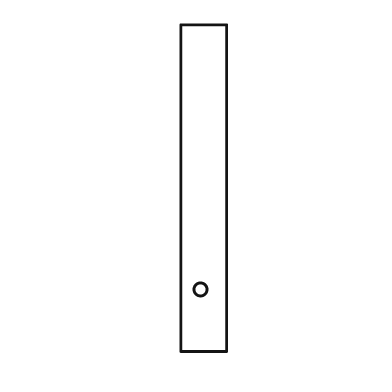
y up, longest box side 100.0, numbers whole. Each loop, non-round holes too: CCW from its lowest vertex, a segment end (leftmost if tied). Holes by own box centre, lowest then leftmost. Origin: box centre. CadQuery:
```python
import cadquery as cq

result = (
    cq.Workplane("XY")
    .moveTo(-7.0, -50.0)
    .lineTo(7.0, -50.0)
    .lineTo(7.0, 50.0)
    .lineTo(-7.0, 50.0)
    .close()
    .moveTo(-1.0, -31.0)
    .circle(2.0)
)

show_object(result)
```